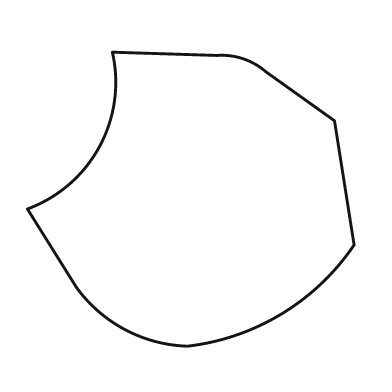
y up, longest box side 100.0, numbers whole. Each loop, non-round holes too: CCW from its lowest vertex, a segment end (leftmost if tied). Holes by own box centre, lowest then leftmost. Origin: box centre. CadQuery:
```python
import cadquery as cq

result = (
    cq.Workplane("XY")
    .moveTo(-1.0, -45.0)
    .threePointArc((28.0, -35.0), (50.0, -14.0))
    .lineTo(44.0, 24.0)
    .lineTo(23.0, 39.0)
    .threePointArc((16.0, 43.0), (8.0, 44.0))
    .lineTo(-24.0, 45.0)
    .threePointArc((-28.0, 16.0), (-50.0, -3.0))
    .lineTo(-35.0, -27.0)
    .threePointArc((-20.0, -40.0), (-1.0, -45.0))
    .close()
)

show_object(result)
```